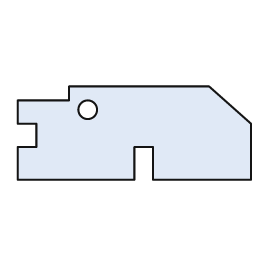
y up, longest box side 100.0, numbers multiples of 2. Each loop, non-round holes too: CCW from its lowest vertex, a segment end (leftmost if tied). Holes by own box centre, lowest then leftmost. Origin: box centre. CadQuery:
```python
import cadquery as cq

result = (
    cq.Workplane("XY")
    .moveTo(-50.0, -20.0)
    .lineTo(0.0, -20.0)
    .lineTo(0.0, -6.0)
    .lineTo(8.0, -6.0)
    .lineTo(8.0, -20.0)
    .lineTo(50.0, -20.0)
    .lineTo(50.0, 4.0)
    .lineTo(32.0, 20.0)
    .lineTo(-28.0, 20.0)
    .lineTo(-28.0, 14.0)
    .lineTo(-50.0, 14.0)
    .lineTo(-50.0, 4.0)
    .lineTo(-42.0, 4.0)
    .lineTo(-42.0, -6.0)
    .lineTo(-50.0, -6.0)
    .close()
    .moveTo(-20.0, 10.0)
    .circle(4.0)
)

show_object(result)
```